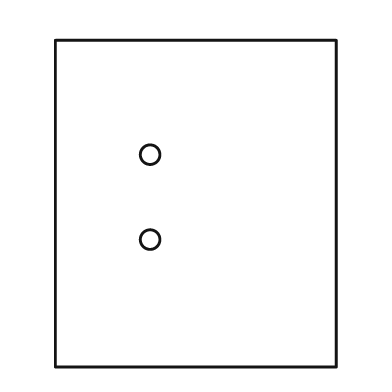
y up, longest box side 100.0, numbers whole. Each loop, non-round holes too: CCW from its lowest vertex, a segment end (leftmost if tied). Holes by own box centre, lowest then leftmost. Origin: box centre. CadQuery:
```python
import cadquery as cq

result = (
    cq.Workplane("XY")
    .moveTo(-43.0, -50.0)
    .lineTo(43.0, -50.0)
    .lineTo(43.0, 50.0)
    .lineTo(-43.0, 50.0)
    .close()
    .moveTo(-14.0, -11.0)
    .circle(3.0)
    .moveTo(-14.0, 15.0)
    .circle(3.0)
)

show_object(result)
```